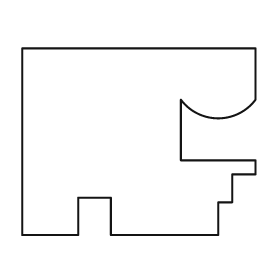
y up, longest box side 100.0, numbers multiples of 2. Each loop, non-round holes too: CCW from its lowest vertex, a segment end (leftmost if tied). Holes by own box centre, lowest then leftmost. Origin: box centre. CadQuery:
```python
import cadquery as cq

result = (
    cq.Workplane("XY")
    .moveTo(-50.0, -40.0)
    .lineTo(-26.0, -40.0)
    .lineTo(-26.0, -24.0)
    .lineTo(-12.0, -24.0)
    .lineTo(-12.0, -40.0)
    .lineTo(34.0, -40.0)
    .lineTo(34.0, -26.0)
    .lineTo(40.0, -26.0)
    .lineTo(40.0, -14.0)
    .lineTo(50.0, -14.0)
    .lineTo(50.0, -8.0)
    .lineTo(18.0, -8.0)
    .lineTo(18.0, 18.0)
    .threePointArc((34.0, 10.0), (50.0, 18.0))
    .lineTo(50.0, 40.0)
    .lineTo(-50.0, 40.0)
    .close()
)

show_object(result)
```